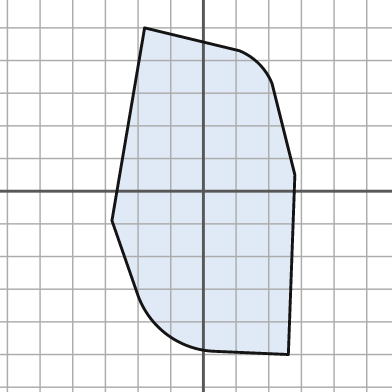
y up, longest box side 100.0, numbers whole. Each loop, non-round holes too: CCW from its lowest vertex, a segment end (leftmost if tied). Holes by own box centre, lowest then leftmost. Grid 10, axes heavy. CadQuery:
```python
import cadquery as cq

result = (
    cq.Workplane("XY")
    .moveTo(26.0, -50.0)
    .lineTo(28.0, 5.0)
    .lineTo(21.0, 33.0)
    .threePointArc((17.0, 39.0), (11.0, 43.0))
    .lineTo(-18.0, 50.0)
    .lineTo(-28.0, -9.0)
    .lineTo(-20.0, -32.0)
    .threePointArc((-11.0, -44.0), (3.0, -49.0))
    .close()
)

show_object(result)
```